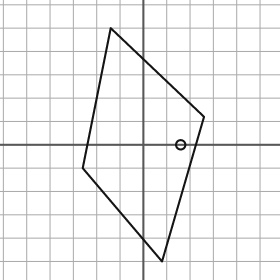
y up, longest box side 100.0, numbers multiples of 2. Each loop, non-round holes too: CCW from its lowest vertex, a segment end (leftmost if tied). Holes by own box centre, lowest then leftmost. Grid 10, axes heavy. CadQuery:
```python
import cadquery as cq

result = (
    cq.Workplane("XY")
    .moveTo(8.0, -50.0)
    .lineTo(26.0, 12.0)
    .lineTo(-14.0, 50.0)
    .lineTo(-26.0, -10.0)
    .close()
    .moveTo(16.0, 0.0)
    .circle(2.0)
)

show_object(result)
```